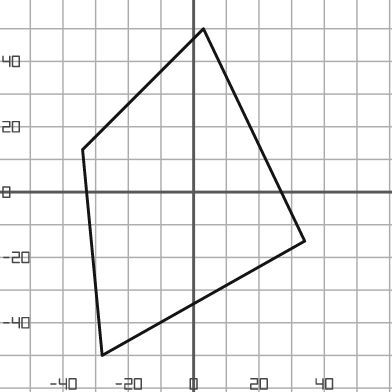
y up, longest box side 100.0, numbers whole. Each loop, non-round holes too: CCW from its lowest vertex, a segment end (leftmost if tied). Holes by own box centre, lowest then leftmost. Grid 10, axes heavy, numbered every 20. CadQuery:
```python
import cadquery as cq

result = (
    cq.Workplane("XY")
    .moveTo(-28.0, -50.0)
    .lineTo(34.0, -15.0)
    .lineTo(3.0, 50.0)
    .lineTo(-34.0, 13.0)
    .close()
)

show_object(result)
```